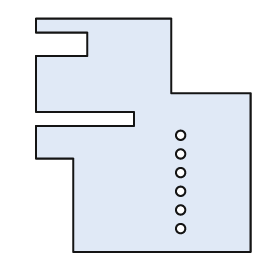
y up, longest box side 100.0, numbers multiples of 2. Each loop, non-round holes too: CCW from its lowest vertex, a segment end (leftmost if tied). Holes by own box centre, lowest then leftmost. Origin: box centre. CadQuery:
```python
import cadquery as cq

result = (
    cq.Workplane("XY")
    .moveTo(-30.0, -50.0)
    .lineTo(46.0, -50.0)
    .lineTo(46.0, 18.0)
    .lineTo(12.0, 18.0)
    .lineTo(12.0, 50.0)
    .lineTo(-46.0, 50.0)
    .lineTo(-46.0, 44.0)
    .lineTo(-24.0, 44.0)
    .lineTo(-24.0, 34.0)
    .lineTo(-46.0, 34.0)
    .lineTo(-46.0, 10.0)
    .lineTo(-4.0, 10.0)
    .lineTo(-4.0, 4.0)
    .lineTo(-46.0, 4.0)
    .lineTo(-46.0, -10.0)
    .lineTo(-30.0, -10.0)
    .close()
    .moveTo(16.0, -40.0)
    .circle(2.0)
    .moveTo(16.0, -32.0)
    .circle(2.0)
    .moveTo(16.0, -24.0)
    .circle(2.0)
    .moveTo(16.0, -16.0)
    .circle(2.0)
    .moveTo(16.0, -8.0)
    .circle(2.0)
    .moveTo(16.0, 0.0)
    .circle(2.0)
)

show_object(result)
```